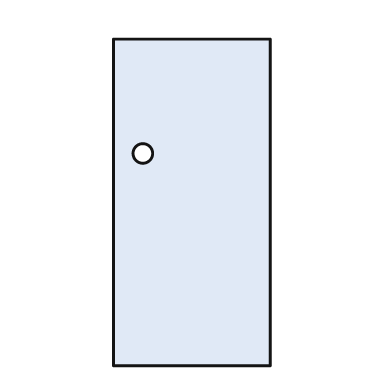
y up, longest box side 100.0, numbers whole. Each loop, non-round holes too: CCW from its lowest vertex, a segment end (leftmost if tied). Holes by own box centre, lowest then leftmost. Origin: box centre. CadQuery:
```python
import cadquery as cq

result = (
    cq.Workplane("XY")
    .moveTo(-24.0, -50.0)
    .lineTo(24.0, -50.0)
    .lineTo(24.0, 50.0)
    .lineTo(-24.0, 50.0)
    .close()
    .moveTo(-15.0, 15.0)
    .circle(3.0)
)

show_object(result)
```